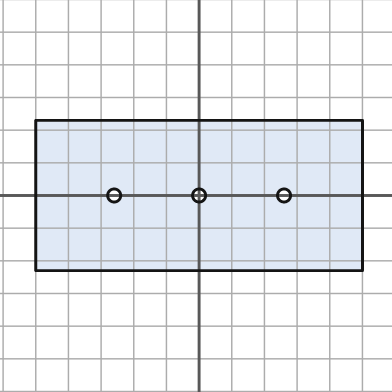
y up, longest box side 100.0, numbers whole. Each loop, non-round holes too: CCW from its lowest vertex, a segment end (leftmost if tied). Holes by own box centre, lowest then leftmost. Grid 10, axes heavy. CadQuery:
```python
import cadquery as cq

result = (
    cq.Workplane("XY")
    .moveTo(-50.0, -23.0)
    .lineTo(50.0, -23.0)
    .lineTo(50.0, 23.0)
    .lineTo(-50.0, 23.0)
    .close()
    .moveTo(-26.0, 0.0)
    .circle(2.0)
    .moveTo(0.0, 0.0)
    .circle(2.0)
    .moveTo(26.0, 0.0)
    .circle(2.0)
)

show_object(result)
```